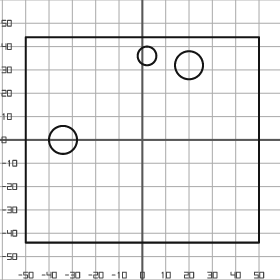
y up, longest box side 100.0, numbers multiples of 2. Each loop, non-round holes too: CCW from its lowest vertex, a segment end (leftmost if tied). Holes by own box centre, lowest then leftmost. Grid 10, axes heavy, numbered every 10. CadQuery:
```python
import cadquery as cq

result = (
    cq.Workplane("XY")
    .moveTo(-50.0, -44.0)
    .lineTo(50.0, -44.0)
    .lineTo(50.0, 44.0)
    .lineTo(-50.0, 44.0)
    .close()
    .moveTo(-34.0, 0.0)
    .circle(6.0)
    .moveTo(20.0, 32.0)
    .circle(6.0)
    .moveTo(2.0, 36.0)
    .circle(4.0)
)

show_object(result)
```